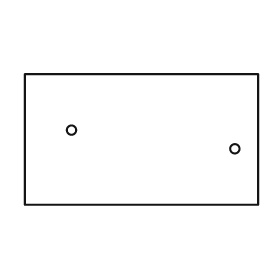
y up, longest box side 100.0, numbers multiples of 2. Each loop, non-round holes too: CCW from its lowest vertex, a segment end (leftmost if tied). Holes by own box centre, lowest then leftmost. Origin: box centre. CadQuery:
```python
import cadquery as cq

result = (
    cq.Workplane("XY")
    .moveTo(-50.0, -28.0)
    .lineTo(50.0, -28.0)
    .lineTo(50.0, 28.0)
    .lineTo(-50.0, 28.0)
    .close()
    .moveTo(40.0, -4.0)
    .circle(2.0)
    .moveTo(-30.0, 4.0)
    .circle(2.0)
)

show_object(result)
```